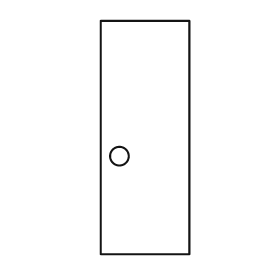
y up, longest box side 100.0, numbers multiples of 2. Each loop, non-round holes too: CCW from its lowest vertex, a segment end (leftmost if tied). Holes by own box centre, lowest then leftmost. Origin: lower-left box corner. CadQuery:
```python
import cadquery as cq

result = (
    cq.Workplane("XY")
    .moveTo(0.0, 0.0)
    .lineTo(38.0, 0.0)
    .lineTo(38.0, 100.0)
    .lineTo(0.0, 100.0)
    .close()
    .moveTo(8.0, 42.0)
    .circle(4.0)
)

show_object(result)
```